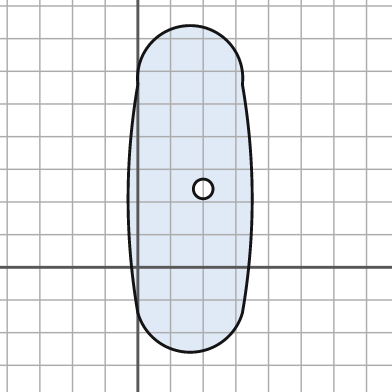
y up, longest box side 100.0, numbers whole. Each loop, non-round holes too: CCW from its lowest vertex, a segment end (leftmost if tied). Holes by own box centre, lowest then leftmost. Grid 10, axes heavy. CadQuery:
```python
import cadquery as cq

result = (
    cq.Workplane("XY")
    .moveTo(0.0, -14.0)
    .threePointArc((16.0, -26.0), (32.0, -14.0))
    .threePointArc((35.0, 21.0), (32.0, 56.0))
    .threePointArc((16.0, 74.0), (0.0, 56.0))
    .threePointArc((-3.0, 21.0), (0.0, -14.0))
    .close()
    .moveTo(20.0, 24.0)
    .circle(3.0)
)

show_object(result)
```